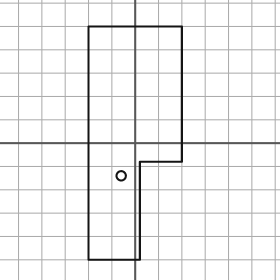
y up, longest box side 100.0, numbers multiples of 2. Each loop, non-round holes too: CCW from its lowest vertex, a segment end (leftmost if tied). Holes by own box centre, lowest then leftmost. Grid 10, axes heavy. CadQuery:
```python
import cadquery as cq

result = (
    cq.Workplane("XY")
    .moveTo(-20.0, -50.0)
    .lineTo(2.0, -50.0)
    .lineTo(2.0, -8.0)
    .lineTo(20.0, -8.0)
    .lineTo(20.0, 50.0)
    .lineTo(-20.0, 50.0)
    .close()
    .moveTo(-6.0, -14.0)
    .circle(2.0)
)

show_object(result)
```